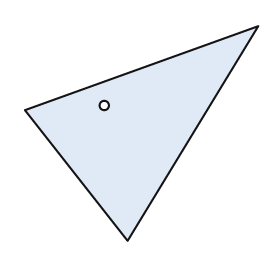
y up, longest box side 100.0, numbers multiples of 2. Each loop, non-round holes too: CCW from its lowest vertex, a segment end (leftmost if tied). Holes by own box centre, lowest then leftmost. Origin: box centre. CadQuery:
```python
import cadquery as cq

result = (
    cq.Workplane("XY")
    .moveTo(-6.0, -46.0)
    .lineTo(50.0, 46.0)
    .lineTo(-50.0, 10.0)
    .close()
    .moveTo(-16.0, 12.0)
    .circle(2.0)
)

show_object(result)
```